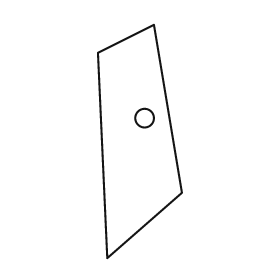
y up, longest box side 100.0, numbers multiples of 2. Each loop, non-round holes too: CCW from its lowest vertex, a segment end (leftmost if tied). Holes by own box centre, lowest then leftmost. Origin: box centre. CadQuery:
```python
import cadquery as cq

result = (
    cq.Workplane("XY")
    .moveTo(-14.0, -50.0)
    .lineTo(18.0, -22.0)
    .lineTo(6.0, 50.0)
    .lineTo(-18.0, 38.0)
    .close()
    .moveTo(2.0, 10.0)
    .circle(4.0)
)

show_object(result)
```